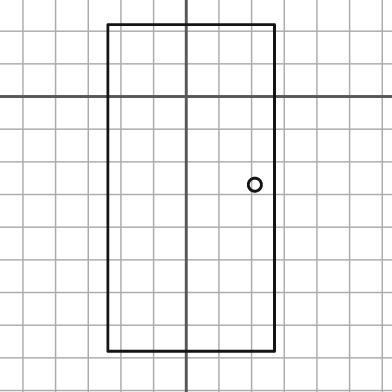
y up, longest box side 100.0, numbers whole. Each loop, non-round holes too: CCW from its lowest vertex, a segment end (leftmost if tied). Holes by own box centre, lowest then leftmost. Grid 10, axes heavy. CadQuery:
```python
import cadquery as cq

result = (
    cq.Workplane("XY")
    .moveTo(-24.0, -78.0)
    .lineTo(27.0, -78.0)
    .lineTo(27.0, 22.0)
    .lineTo(-24.0, 22.0)
    .close()
    .moveTo(21.0, -27.0)
    .circle(2.0)
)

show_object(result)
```